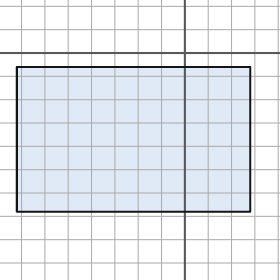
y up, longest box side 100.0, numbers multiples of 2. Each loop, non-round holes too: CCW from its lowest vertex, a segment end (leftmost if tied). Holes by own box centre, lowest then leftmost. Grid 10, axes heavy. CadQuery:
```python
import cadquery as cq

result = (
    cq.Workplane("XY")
    .moveTo(-72.0, -68.0)
    .lineTo(28.0, -68.0)
    .lineTo(28.0, -6.0)
    .lineTo(-72.0, -6.0)
    .close()
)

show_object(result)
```